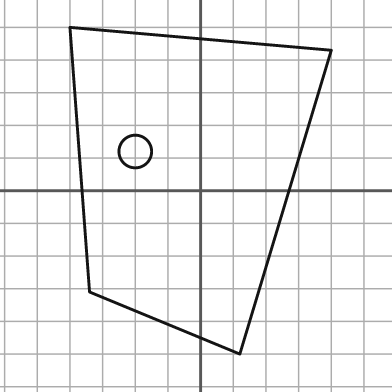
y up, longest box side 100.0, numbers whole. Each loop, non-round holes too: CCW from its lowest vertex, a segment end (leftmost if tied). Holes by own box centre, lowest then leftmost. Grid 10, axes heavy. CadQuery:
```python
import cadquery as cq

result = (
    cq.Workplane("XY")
    .moveTo(12.0, -50.0)
    .lineTo(40.0, 43.0)
    .lineTo(-40.0, 50.0)
    .lineTo(-34.0, -31.0)
    .close()
    .moveTo(-20.0, 12.0)
    .circle(5.0)
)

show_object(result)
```